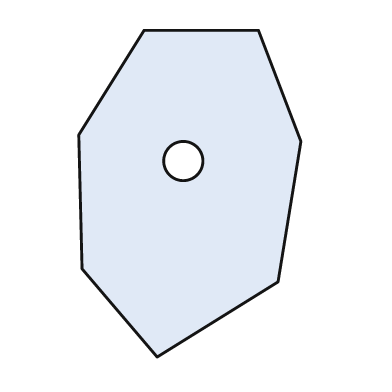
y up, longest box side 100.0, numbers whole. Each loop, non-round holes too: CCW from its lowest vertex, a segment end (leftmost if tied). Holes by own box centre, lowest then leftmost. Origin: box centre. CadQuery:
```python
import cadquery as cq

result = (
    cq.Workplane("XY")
    .moveTo(-10.0, -50.0)
    .lineTo(27.0, -27.0)
    .lineTo(34.0, 16.0)
    .lineTo(21.0, 50.0)
    .lineTo(-14.0, 50.0)
    .lineTo(-34.0, 18.0)
    .lineTo(-33.0, -23.0)
    .close()
    .moveTo(-2.0, 10.0)
    .circle(6.0)
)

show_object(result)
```